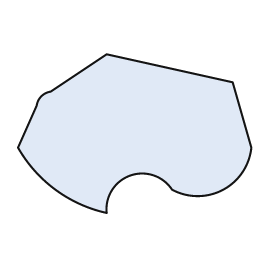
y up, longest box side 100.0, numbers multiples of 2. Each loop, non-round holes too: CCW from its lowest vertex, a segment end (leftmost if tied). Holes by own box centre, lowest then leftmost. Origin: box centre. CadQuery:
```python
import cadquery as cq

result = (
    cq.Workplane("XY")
    .moveTo(-12.0, -34.0)
    .threePointArc((-2.0, -18.0), (16.0, -24.0))
    .threePointArc((38.0, -24.0), (50.0, -6.0))
    .lineTo(42.0, 22.0)
    .lineTo(-12.0, 34.0)
    .lineTo(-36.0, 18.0)
    .threePointArc((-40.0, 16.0), (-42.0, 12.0))
    .lineTo(-50.0, -6.0)
    .threePointArc((-34.0, -24.0), (-12.0, -34.0))
    .close()
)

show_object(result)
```